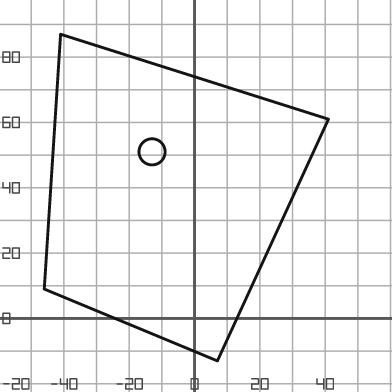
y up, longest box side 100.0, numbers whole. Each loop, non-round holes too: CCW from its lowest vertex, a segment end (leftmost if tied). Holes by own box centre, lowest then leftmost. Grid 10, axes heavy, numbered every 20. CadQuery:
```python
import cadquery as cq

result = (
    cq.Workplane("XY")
    .moveTo(7.0, -13.0)
    .lineTo(41.0, 61.0)
    .lineTo(-41.0, 87.0)
    .lineTo(-46.0, 9.0)
    .close()
    .moveTo(-13.0, 51.0)
    .circle(4.0)
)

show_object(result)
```